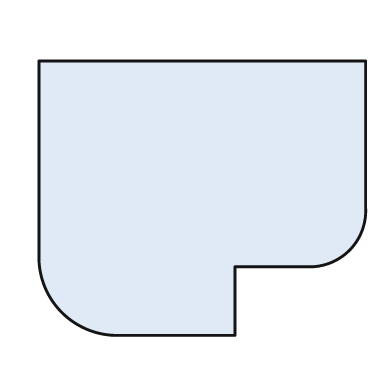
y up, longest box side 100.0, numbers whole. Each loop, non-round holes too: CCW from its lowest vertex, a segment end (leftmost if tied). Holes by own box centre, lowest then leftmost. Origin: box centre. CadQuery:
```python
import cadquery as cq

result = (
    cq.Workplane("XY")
    .moveTo(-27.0, -42.0)
    .lineTo(10.0, -42.0)
    .lineTo(10.0, -21.0)
    .lineTo(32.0, -21.0)
    .threePointArc((45.0, -16.0), (50.0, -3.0))
    .lineTo(50.0, 42.0)
    .lineTo(-50.0, 42.0)
    .lineTo(-50.0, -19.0)
    .threePointArc((-43.0, -35.0), (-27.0, -42.0))
    .close()
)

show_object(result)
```